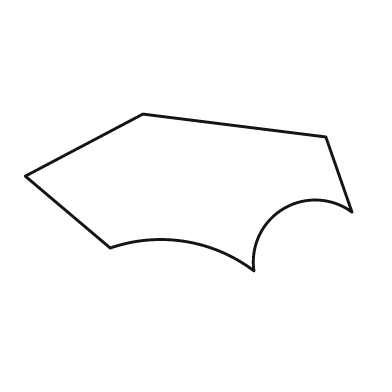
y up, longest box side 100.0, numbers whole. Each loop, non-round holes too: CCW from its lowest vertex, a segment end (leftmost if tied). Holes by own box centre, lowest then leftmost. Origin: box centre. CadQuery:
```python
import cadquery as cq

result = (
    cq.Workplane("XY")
    .moveTo(20.0, -24.0)
    .threePointArc((29.0, -5.0), (50.0, -6.0))
    .lineTo(42.0, 17.0)
    .lineTo(-14.0, 24.0)
    .lineTo(-50.0, 5.0)
    .lineTo(-24.0, -17.0)
    .threePointArc((-1.0, -15.0), (20.0, -24.0))
    .close()
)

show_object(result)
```